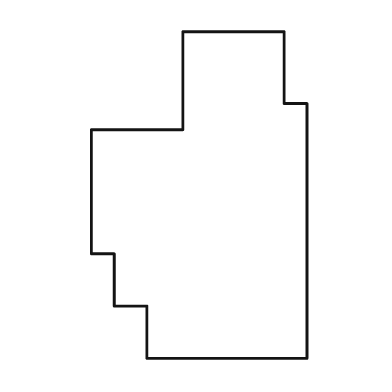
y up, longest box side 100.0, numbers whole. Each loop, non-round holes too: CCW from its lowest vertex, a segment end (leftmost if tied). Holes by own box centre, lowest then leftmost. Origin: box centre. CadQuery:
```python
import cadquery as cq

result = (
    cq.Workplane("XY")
    .moveTo(-16.0, -50.0)
    .lineTo(33.0, -50.0)
    .lineTo(33.0, 28.0)
    .lineTo(26.0, 28.0)
    .lineTo(26.0, 50.0)
    .lineTo(-5.0, 50.0)
    .lineTo(-5.0, 20.0)
    .lineTo(-33.0, 20.0)
    .lineTo(-33.0, -18.0)
    .lineTo(-26.0, -18.0)
    .lineTo(-26.0, -34.0)
    .lineTo(-16.0, -34.0)
    .close()
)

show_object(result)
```